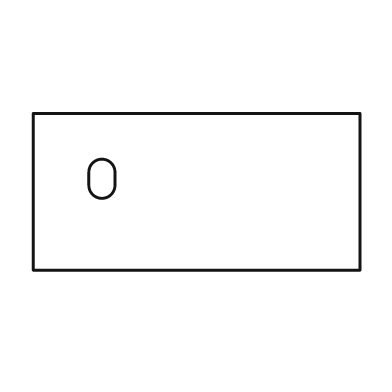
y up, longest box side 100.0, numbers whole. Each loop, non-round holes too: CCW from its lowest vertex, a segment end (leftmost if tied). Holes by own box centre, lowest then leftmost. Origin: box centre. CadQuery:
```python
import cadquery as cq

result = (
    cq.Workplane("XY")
    .moveTo(-50.0, -24.0)
    .lineTo(50.0, -24.0)
    .lineTo(50.0, 24.0)
    .lineTo(-50.0, 24.0)
    .close()
    .moveTo(-33.0, 2.0)
    .threePointArc((-29.0, -2.0), (-25.0, 2.0))
    .lineTo(-25.0, 6.0)
    .threePointArc((-29.0, 10.0), (-33.0, 6.0))
    .close()
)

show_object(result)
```